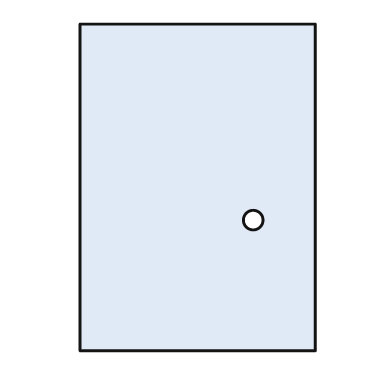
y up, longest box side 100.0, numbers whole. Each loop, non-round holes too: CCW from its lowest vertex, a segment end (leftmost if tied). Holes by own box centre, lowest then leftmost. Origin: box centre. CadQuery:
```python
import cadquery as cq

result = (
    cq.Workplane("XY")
    .moveTo(-36.0, -50.0)
    .lineTo(36.0, -50.0)
    .lineTo(36.0, 50.0)
    .lineTo(-36.0, 50.0)
    .close()
    .moveTo(17.0, -10.0)
    .circle(3.0)
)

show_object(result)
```